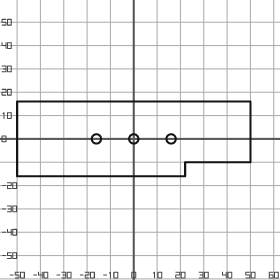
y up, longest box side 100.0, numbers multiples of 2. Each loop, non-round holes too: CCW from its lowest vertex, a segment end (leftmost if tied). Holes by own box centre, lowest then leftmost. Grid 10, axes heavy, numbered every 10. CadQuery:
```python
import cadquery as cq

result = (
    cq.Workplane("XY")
    .moveTo(-50.0, -16.0)
    .lineTo(22.0, -16.0)
    .lineTo(22.0, -10.0)
    .lineTo(50.0, -10.0)
    .lineTo(50.0, 16.0)
    .lineTo(-50.0, 16.0)
    .close()
    .moveTo(-16.0, 0.0)
    .circle(2.0)
    .moveTo(0.0, 0.0)
    .circle(2.0)
    .moveTo(16.0, 0.0)
    .circle(2.0)
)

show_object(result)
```